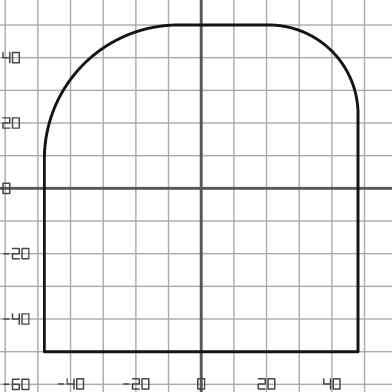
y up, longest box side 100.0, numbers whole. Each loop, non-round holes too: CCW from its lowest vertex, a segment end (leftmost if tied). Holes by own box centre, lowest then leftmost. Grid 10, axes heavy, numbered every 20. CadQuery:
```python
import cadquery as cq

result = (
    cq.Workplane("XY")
    .moveTo(-48.0, -50.0)
    .lineTo(48.0, -50.0)
    .lineTo(48.0, 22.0)
    .threePointArc((40.0, 42.0), (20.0, 50.0))
    .lineTo(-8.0, 50.0)
    .threePointArc((-36.0, 38.0), (-48.0, 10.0))
    .close()
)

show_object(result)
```